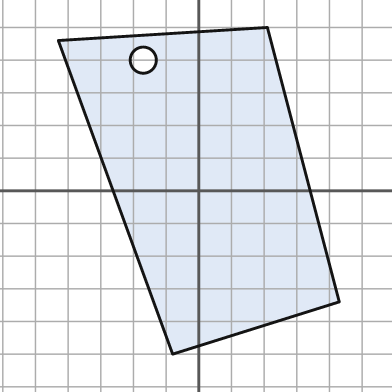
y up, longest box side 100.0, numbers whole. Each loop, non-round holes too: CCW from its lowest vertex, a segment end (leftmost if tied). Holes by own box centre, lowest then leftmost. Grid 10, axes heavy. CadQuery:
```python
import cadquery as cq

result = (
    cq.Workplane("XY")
    .moveTo(-8.0, -50.0)
    .lineTo(43.0, -34.0)
    .lineTo(21.0, 50.0)
    .lineTo(-43.0, 46.0)
    .close()
    .moveTo(-17.0, 40.0)
    .circle(4.0)
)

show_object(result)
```